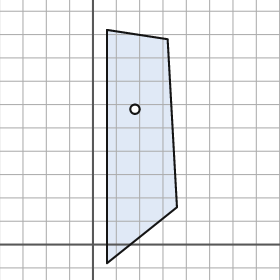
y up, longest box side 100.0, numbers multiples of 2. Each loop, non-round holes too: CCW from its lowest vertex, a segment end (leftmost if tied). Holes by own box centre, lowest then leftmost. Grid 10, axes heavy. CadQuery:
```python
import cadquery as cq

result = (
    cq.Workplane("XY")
    .moveTo(6.0, -8.0)
    .lineTo(36.0, 16.0)
    .lineTo(32.0, 88.0)
    .lineTo(6.0, 92.0)
    .close()
    .moveTo(18.0, 58.0)
    .circle(2.0)
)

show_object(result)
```